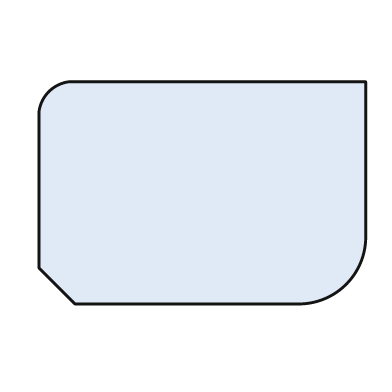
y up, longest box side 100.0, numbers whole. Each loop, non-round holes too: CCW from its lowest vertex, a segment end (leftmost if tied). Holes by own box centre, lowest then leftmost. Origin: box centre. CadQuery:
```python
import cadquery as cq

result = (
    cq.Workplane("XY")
    .moveTo(-39.0, -34.0)
    .lineTo(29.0, -34.0)
    .threePointArc((44.0, -28.0), (50.0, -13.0))
    .lineTo(50.0, 34.0)
    .lineTo(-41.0, 34.0)
    .threePointArc((-47.0, 31.0), (-50.0, 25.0))
    .lineTo(-50.0, -23.0)
    .close()
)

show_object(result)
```